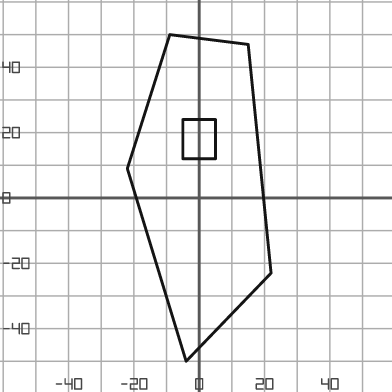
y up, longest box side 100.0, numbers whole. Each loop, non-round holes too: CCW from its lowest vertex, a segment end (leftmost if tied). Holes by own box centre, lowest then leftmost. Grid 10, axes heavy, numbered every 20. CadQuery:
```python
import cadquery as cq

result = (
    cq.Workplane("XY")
    .moveTo(-4.0, -50.0)
    .lineTo(22.0, -23.0)
    .lineTo(15.0, 47.0)
    .lineTo(-9.0, 50.0)
    .lineTo(-22.0, 9.0)
    .close()
    .moveTo(-5.0, 12.0)
    .lineTo(5.0, 12.0)
    .lineTo(5.0, 24.0)
    .lineTo(-5.0, 24.0)
    .close()
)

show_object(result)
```